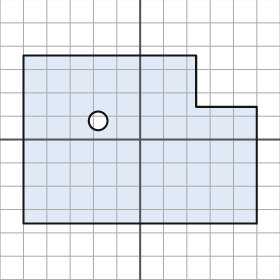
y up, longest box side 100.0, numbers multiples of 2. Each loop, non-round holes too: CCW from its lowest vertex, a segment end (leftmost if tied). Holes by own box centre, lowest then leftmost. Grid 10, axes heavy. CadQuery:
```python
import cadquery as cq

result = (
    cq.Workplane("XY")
    .moveTo(-50.0, -36.0)
    .lineTo(50.0, -36.0)
    .lineTo(50.0, 14.0)
    .lineTo(24.0, 14.0)
    .lineTo(24.0, 36.0)
    .lineTo(-50.0, 36.0)
    .close()
    .moveTo(-18.0, 8.0)
    .circle(4.0)
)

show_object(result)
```